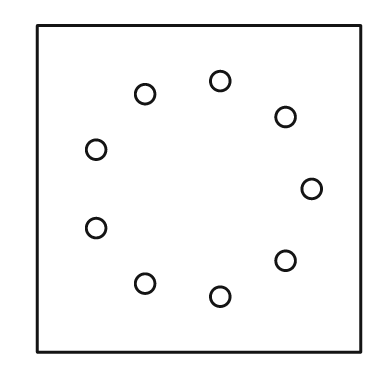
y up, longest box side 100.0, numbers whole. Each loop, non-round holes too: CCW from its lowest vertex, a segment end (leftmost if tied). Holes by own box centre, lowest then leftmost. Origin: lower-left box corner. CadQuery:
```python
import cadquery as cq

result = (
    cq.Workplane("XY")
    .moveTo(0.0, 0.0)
    .lineTo(99.0, 0.0)
    .lineTo(99.0, 100.0)
    .lineTo(0.0, 100.0)
    .close()
    .moveTo(56.0, 17.0)
    .circle(3.0)
    .moveTo(33.0, 21.0)
    .circle(3.0)
    .moveTo(76.0, 28.0)
    .circle(3.0)
    .moveTo(18.0, 38.0)
    .circle(3.0)
    .moveTo(84.0, 50.0)
    .circle(3.0)
    .moveTo(18.0, 62.0)
    .circle(3.0)
    .moveTo(76.0, 72.0)
    .circle(3.0)
    .moveTo(33.0, 79.0)
    .circle(3.0)
    .moveTo(56.0, 83.0)
    .circle(3.0)
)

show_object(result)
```